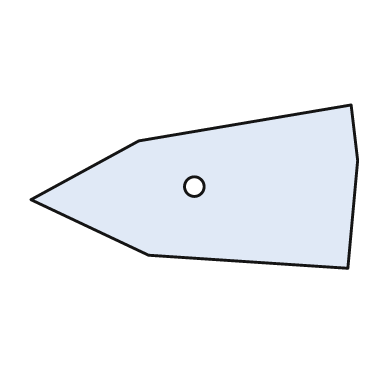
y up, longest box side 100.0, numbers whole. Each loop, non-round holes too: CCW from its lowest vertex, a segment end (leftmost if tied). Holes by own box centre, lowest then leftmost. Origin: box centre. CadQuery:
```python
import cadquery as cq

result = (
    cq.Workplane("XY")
    .moveTo(47.0, -25.0)
    .lineTo(50.0, 8.0)
    .lineTo(48.0, 25.0)
    .lineTo(-17.0, 14.0)
    .lineTo(-50.0, -4.0)
    .lineTo(-14.0, -21.0)
    .close()
    .moveTo(0.0, 0.0)
    .circle(3.0)
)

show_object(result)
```